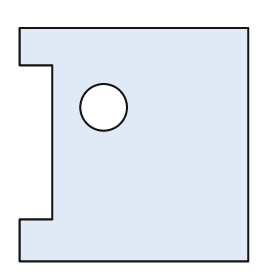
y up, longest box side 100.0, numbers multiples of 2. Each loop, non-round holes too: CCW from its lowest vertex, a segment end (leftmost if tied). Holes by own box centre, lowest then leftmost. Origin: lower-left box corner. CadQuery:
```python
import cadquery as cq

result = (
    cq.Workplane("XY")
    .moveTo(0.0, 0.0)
    .lineTo(98.0, 0.0)
    .lineTo(98.0, 100.0)
    .lineTo(0.0, 100.0)
    .lineTo(0.0, 84.0)
    .lineTo(14.0, 84.0)
    .lineTo(14.0, 18.0)
    .lineTo(0.0, 18.0)
    .close()
    .moveTo(36.0, 66.0)
    .circle(10.0)
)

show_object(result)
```